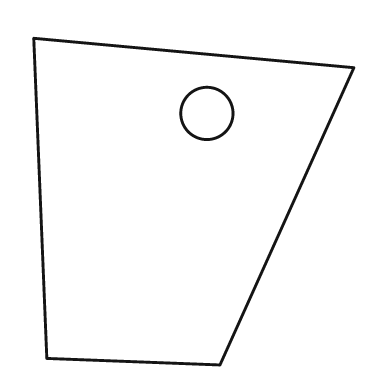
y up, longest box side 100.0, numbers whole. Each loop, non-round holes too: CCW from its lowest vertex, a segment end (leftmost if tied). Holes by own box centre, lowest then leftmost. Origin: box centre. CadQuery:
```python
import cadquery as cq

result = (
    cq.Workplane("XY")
    .moveTo(8.0, -50.0)
    .lineTo(49.0, 41.0)
    .lineTo(-49.0, 50.0)
    .lineTo(-45.0, -48.0)
    .close()
    .moveTo(4.0, 27.0)
    .circle(8.0)
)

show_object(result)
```